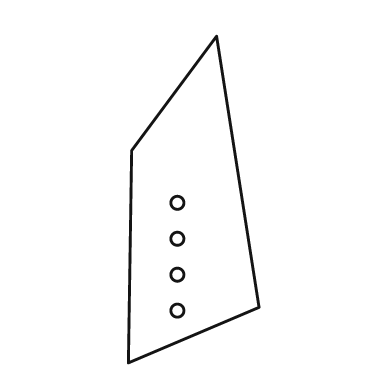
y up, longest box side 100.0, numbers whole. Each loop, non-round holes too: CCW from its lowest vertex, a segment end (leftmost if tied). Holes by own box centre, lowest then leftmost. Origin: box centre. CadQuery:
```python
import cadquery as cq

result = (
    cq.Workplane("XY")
    .moveTo(-20.0, -50.0)
    .lineTo(20.0, -33.0)
    .lineTo(7.0, 50.0)
    .lineTo(-19.0, 15.0)
    .close()
    .moveTo(-5.0, -34.0)
    .circle(2.0)
    .moveTo(-5.0, -23.0)
    .circle(2.0)
    .moveTo(-5.0, -12.0)
    .circle(2.0)
    .moveTo(-5.0, -1.0)
    .circle(2.0)
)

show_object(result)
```